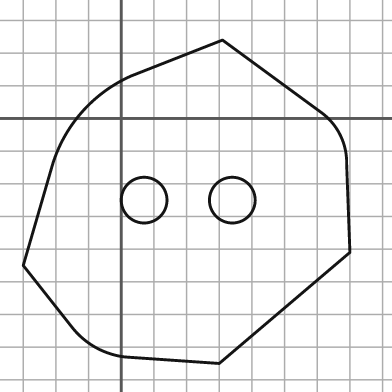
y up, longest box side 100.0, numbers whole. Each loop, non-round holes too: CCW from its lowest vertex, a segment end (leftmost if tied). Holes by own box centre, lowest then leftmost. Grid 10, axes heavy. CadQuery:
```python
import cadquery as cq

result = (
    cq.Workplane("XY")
    .moveTo(30.0, -75.0)
    .lineTo(70.0, -41.0)
    .lineTo(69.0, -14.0)
    .threePointArc((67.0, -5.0), (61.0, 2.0))
    .lineTo(31.0, 24.0)
    .lineTo(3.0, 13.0)
    .threePointArc((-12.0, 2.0), (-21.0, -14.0))
    .lineTo(-30.0, -45.0)
    .lineTo(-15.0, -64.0)
    .threePointArc((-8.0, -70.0), (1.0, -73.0))
    .close()
    .moveTo(7.0, -25.0)
    .circle(7.0)
    .moveTo(34.0, -25.0)
    .circle(7.0)
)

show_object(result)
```